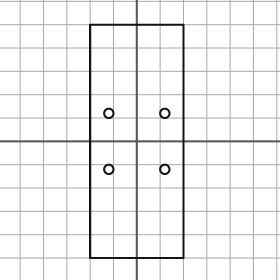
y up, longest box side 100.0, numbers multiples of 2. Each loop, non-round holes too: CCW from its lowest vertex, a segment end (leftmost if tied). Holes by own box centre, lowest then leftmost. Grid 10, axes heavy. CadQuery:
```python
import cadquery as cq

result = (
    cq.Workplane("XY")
    .moveTo(-20.0, -50.0)
    .lineTo(20.0, -50.0)
    .lineTo(20.0, 50.0)
    .lineTo(-20.0, 50.0)
    .close()
    .moveTo(-12.0, -12.0)
    .circle(2.0)
    .moveTo(12.0, -12.0)
    .circle(2.0)
    .moveTo(-12.0, 12.0)
    .circle(2.0)
    .moveTo(12.0, 12.0)
    .circle(2.0)
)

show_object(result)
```